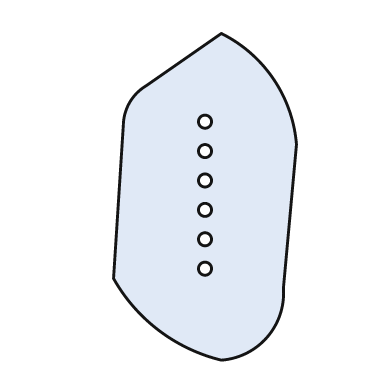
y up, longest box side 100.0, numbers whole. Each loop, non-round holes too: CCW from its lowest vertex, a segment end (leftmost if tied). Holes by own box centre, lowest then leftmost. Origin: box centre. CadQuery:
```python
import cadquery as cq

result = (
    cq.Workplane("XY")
    .moveTo(5.0, -50.0)
    .threePointArc((19.0, -43.0), (24.0, -28.0))
    .lineTo(28.0, 16.0)
    .threePointArc((21.0, 36.0), (5.0, 50.0))
    .lineTo(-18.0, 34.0)
    .threePointArc((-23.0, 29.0), (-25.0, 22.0))
    .lineTo(-28.0, -25.0)
    .threePointArc((-14.0, -41.0), (5.0, -50.0))
    .close()
    .moveTo(0.0, -22.0)
    .circle(2.0)
    .moveTo(0.0, -13.0)
    .circle(2.0)
    .moveTo(0.0, -4.0)
    .circle(2.0)
    .moveTo(0.0, 5.0)
    .circle(2.0)
    .moveTo(0.0, 14.0)
    .circle(2.0)
    .moveTo(0.0, 23.0)
    .circle(2.0)
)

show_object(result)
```